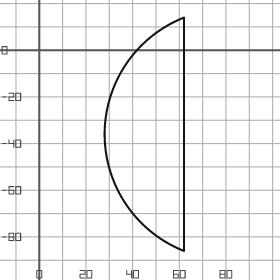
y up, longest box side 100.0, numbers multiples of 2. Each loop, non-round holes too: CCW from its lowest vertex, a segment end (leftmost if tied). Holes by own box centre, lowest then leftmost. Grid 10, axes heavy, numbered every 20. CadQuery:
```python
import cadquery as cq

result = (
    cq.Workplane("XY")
    .moveTo(62.0, -86.0)
    .lineTo(62.0, 14.0)
    .threePointArc((28.0, -36.0), (62.0, -86.0))
    .close()
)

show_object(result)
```